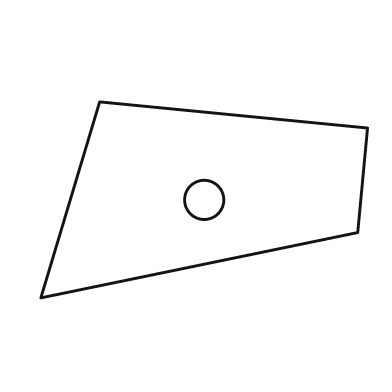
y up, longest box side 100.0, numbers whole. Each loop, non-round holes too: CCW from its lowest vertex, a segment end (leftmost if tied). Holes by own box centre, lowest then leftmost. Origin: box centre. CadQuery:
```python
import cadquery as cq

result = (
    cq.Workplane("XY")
    .moveTo(-50.0, -30.0)
    .lineTo(47.0, -10.0)
    .lineTo(50.0, 22.0)
    .lineTo(-32.0, 30.0)
    .close()
    .moveTo(0.0, 0.0)
    .circle(6.0)
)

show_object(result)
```